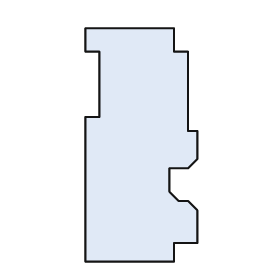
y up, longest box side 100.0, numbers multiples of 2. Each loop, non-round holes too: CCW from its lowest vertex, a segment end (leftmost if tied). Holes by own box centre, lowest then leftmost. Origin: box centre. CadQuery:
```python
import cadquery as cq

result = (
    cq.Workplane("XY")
    .moveTo(-24.0, -50.0)
    .lineTo(14.0, -50.0)
    .lineTo(14.0, -42.0)
    .lineTo(24.0, -42.0)
    .lineTo(24.0, -28.0)
    .lineTo(20.0, -24.0)
    .lineTo(16.0, -24.0)
    .lineTo(12.0, -20.0)
    .lineTo(12.0, -10.0)
    .lineTo(20.0, -10.0)
    .lineTo(24.0, -6.0)
    .lineTo(24.0, 6.0)
    .lineTo(20.0, 6.0)
    .lineTo(20.0, 40.0)
    .lineTo(14.0, 40.0)
    .lineTo(14.0, 50.0)
    .lineTo(-24.0, 50.0)
    .lineTo(-24.0, 40.0)
    .lineTo(-18.0, 40.0)
    .lineTo(-18.0, 12.0)
    .lineTo(-24.0, 12.0)
    .close()
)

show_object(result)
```